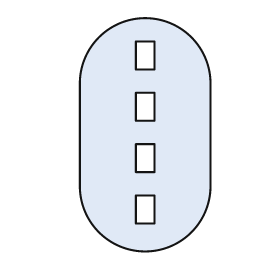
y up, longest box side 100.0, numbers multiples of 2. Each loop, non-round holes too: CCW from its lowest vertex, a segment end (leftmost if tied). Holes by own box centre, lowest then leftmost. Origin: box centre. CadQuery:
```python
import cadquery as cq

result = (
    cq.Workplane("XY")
    .moveTo(-28.0, -22.0)
    .threePointArc((0.0, -50.0), (28.0, -22.0))
    .lineTo(28.0, 22.0)
    .threePointArc((0.0, 50.0), (-28.0, 22.0))
    .close()
    .moveTo(-4.0, -38.0)
    .lineTo(4.0, -38.0)
    .lineTo(4.0, -26.0)
    .lineTo(-4.0, -26.0)
    .close()
    .moveTo(-4.0, -16.0)
    .lineTo(4.0, -16.0)
    .lineTo(4.0, -4.0)
    .lineTo(-4.0, -4.0)
    .close()
    .moveTo(-4.0, 6.0)
    .lineTo(4.0, 6.0)
    .lineTo(4.0, 18.0)
    .lineTo(-4.0, 18.0)
    .close()
    .moveTo(-4.0, 28.0)
    .lineTo(4.0, 28.0)
    .lineTo(4.0, 40.0)
    .lineTo(-4.0, 40.0)
    .close()
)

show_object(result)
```